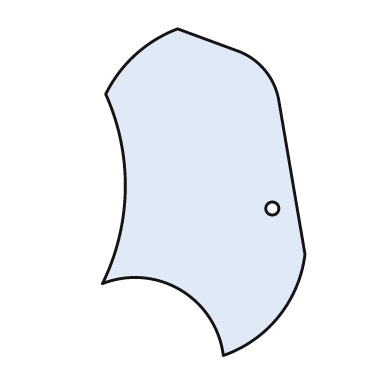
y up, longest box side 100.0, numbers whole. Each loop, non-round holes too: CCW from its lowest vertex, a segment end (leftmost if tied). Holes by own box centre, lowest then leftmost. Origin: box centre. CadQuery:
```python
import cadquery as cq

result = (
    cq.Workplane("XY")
    .moveTo(6.0, -50.0)
    .threePointArc((23.0, -38.0), (31.0, -19.0))
    .lineTo(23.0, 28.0)
    .threePointArc((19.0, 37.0), (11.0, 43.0))
    .lineTo(-8.0, 50.0)
    .threePointArc((-21.0, 42.0), (-30.0, 30.0))
    .threePointArc((-24.0, 1.0), (-31.0, -28.0))
    .threePointArc((-7.0, -30.0), (6.0, -50.0))
    .close()
    .moveTo(21.0, -5.0)
    .circle(2.0)
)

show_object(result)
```